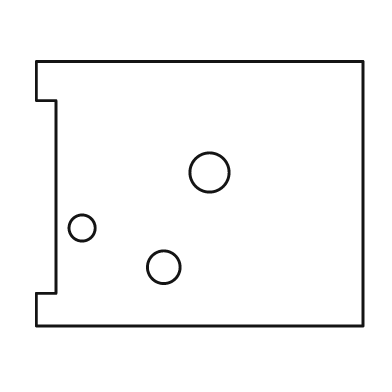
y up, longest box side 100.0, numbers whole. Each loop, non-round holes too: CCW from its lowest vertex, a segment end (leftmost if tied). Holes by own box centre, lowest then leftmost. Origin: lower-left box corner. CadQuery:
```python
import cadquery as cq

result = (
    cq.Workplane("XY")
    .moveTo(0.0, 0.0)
    .lineTo(100.0, 0.0)
    .lineTo(100.0, 81.0)
    .lineTo(0.0, 81.0)
    .lineTo(0.0, 69.0)
    .lineTo(6.0, 69.0)
    .lineTo(6.0, 10.0)
    .lineTo(0.0, 10.0)
    .close()
    .moveTo(39.0, 18.0)
    .circle(5.0)
    .moveTo(14.0, 30.0)
    .circle(4.0)
    .moveTo(53.0, 47.0)
    .circle(6.0)
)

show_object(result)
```